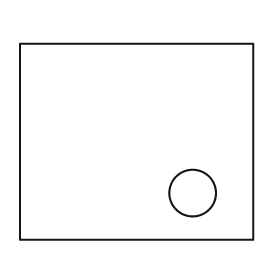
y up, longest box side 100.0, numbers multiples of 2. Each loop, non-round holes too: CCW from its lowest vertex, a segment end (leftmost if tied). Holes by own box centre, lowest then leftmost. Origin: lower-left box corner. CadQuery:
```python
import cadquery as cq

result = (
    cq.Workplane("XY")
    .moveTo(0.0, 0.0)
    .lineTo(100.0, 0.0)
    .lineTo(100.0, 84.0)
    .lineTo(0.0, 84.0)
    .close()
    .moveTo(74.0, 20.0)
    .circle(10.0)
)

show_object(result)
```